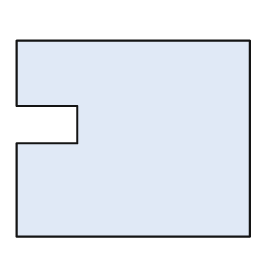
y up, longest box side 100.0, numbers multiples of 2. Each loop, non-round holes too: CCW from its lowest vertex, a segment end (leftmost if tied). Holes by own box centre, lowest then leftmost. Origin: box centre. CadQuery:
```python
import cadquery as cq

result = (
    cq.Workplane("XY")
    .moveTo(-50.0, -42.0)
    .lineTo(50.0, -42.0)
    .lineTo(50.0, 42.0)
    .lineTo(-50.0, 42.0)
    .lineTo(-50.0, 14.0)
    .lineTo(-24.0, 14.0)
    .lineTo(-24.0, -2.0)
    .lineTo(-50.0, -2.0)
    .close()
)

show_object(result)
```